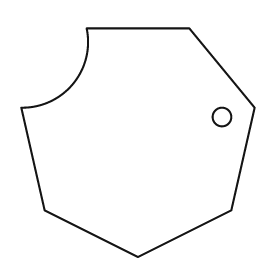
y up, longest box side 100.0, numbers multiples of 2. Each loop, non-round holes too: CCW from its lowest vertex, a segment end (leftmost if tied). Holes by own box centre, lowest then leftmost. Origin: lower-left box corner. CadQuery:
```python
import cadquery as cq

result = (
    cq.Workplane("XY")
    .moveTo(50.0, 0.0)
    .lineTo(90.0, 20.0)
    .lineTo(100.0, 64.0)
    .lineTo(72.0, 98.0)
    .lineTo(28.0, 98.0)
    .threePointArc((22.0, 74.0), (0.0, 64.0))
    .lineTo(10.0, 20.0)
    .close()
    .moveTo(86.0, 60.0)
    .circle(4.0)
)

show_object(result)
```